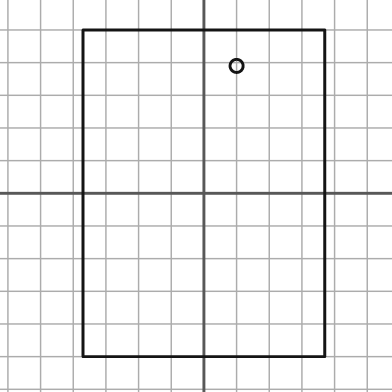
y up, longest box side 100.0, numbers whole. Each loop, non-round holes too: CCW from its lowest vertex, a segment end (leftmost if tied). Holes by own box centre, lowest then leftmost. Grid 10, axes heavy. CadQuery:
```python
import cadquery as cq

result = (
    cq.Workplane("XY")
    .moveTo(-37.0, -50.0)
    .lineTo(37.0, -50.0)
    .lineTo(37.0, 50.0)
    .lineTo(-37.0, 50.0)
    .close()
    .moveTo(10.0, 39.0)
    .circle(2.0)
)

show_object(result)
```